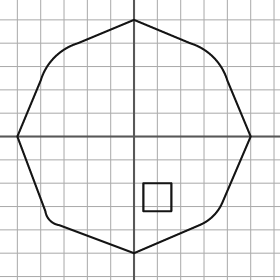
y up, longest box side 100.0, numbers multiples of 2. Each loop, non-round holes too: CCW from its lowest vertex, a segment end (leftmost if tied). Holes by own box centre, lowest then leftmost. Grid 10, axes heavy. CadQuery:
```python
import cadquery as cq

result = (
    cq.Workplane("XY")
    .moveTo(0.0, -50.0)
    .lineTo(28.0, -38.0)
    .threePointArc((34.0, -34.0), (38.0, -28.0))
    .lineTo(50.0, 0.0)
    .lineTo(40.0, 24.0)
    .threePointArc((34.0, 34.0), (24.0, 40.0))
    .lineTo(0.0, 50.0)
    .lineTo(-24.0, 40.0)
    .threePointArc((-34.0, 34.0), (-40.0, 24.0))
    .lineTo(-50.0, 0.0)
    .lineTo(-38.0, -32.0)
    .threePointArc((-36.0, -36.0), (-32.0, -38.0))
    .close()
    .moveTo(4.0, -32.0)
    .lineTo(16.0, -32.0)
    .lineTo(16.0, -20.0)
    .lineTo(4.0, -20.0)
    .close()
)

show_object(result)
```